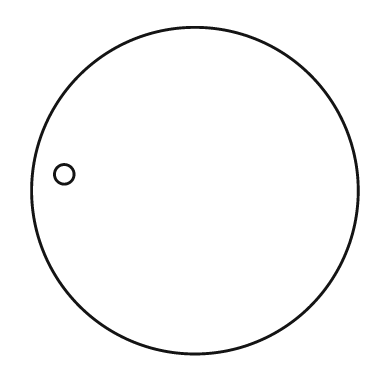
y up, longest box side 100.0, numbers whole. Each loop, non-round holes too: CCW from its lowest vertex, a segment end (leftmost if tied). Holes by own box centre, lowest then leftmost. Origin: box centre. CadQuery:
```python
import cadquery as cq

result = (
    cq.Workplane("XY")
    .moveTo(0.0, 0.0)
    .circle(50.0)
    .moveTo(-40.0, 5.0)
    .circle(3.0)
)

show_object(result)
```